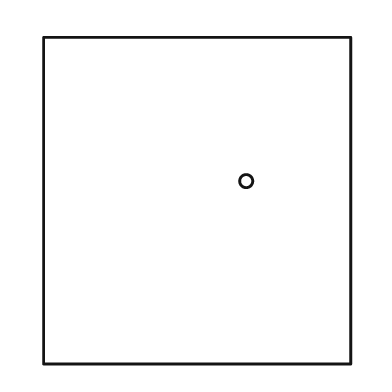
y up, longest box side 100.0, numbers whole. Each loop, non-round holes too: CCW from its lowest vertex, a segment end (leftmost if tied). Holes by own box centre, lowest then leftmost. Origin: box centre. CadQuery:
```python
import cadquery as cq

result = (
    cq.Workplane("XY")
    .moveTo(-47.0, -50.0)
    .lineTo(47.0, -50.0)
    .lineTo(47.0, 50.0)
    .lineTo(-47.0, 50.0)
    .close()
    .moveTo(15.0, 6.0)
    .circle(2.0)
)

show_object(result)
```